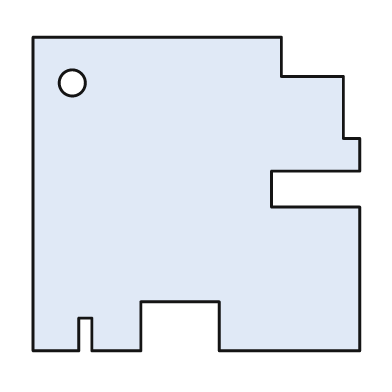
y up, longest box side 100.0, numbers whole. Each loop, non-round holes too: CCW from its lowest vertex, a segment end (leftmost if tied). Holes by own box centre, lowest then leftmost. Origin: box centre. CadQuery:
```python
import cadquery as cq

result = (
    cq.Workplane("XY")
    .moveTo(-50.0, -48.0)
    .lineTo(-36.0, -48.0)
    .lineTo(-36.0, -38.0)
    .lineTo(-32.0, -38.0)
    .lineTo(-32.0, -48.0)
    .lineTo(-17.0, -48.0)
    .lineTo(-17.0, -33.0)
    .lineTo(7.0, -33.0)
    .lineTo(7.0, -48.0)
    .lineTo(50.0, -48.0)
    .lineTo(50.0, -4.0)
    .lineTo(23.0, -4.0)
    .lineTo(23.0, 7.0)
    .lineTo(50.0, 7.0)
    .lineTo(50.0, 17.0)
    .lineTo(45.0, 17.0)
    .lineTo(45.0, 36.0)
    .lineTo(26.0, 36.0)
    .lineTo(26.0, 48.0)
    .lineTo(-50.0, 48.0)
    .close()
    .moveTo(-38.0, 34.0)
    .circle(4.0)
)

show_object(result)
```